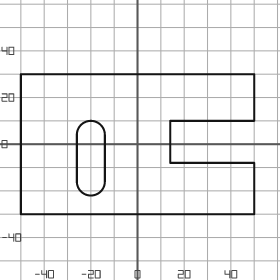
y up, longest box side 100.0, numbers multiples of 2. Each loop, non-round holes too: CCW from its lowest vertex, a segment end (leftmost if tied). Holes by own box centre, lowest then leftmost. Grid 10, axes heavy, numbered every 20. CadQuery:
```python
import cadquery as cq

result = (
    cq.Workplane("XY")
    .moveTo(-50.0, -30.0)
    .lineTo(50.0, -30.0)
    .lineTo(50.0, -8.0)
    .lineTo(14.0, -8.0)
    .lineTo(14.0, 10.0)
    .lineTo(50.0, 10.0)
    .lineTo(50.0, 30.0)
    .lineTo(-50.0, 30.0)
    .close()
    .moveTo(-26.0, -16.0)
    .threePointArc((-20.0, -22.0), (-14.0, -16.0))
    .lineTo(-14.0, 4.0)
    .threePointArc((-20.0, 10.0), (-26.0, 4.0))
    .close()
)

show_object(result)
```